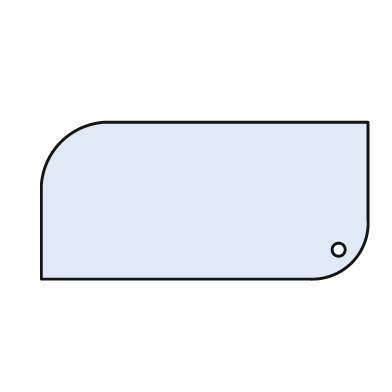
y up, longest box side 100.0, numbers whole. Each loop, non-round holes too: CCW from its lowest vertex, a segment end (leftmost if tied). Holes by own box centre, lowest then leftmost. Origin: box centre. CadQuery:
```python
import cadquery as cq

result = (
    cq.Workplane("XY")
    .moveTo(-50.0, -24.0)
    .lineTo(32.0, -24.0)
    .threePointArc((45.0, -19.0), (50.0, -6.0))
    .lineTo(50.0, 24.0)
    .lineTo(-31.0, 24.0)
    .threePointArc((-44.0, 18.0), (-50.0, 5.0))
    .close()
    .moveTo(41.0, -15.0)
    .circle(2.0)
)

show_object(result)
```